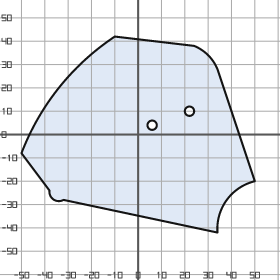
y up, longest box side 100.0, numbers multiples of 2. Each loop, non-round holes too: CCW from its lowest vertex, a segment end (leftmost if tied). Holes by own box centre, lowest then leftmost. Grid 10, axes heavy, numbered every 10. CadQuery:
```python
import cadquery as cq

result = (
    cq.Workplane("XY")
    .moveTo(34.0, -42.0)
    .threePointArc((38.0, -28.0), (50.0, -20.0))
    .lineTo(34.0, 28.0)
    .threePointArc((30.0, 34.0), (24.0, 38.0))
    .lineTo(-10.0, 42.0)
    .threePointArc((-34.0, 20.0), (-50.0, -8.0))
    .lineTo(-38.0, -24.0)
    .threePointArc((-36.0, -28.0), (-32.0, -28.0))
    .close()
    .moveTo(6.0, 4.0)
    .circle(2.0)
    .moveTo(22.0, 10.0)
    .circle(2.0)
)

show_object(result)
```